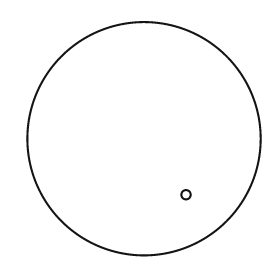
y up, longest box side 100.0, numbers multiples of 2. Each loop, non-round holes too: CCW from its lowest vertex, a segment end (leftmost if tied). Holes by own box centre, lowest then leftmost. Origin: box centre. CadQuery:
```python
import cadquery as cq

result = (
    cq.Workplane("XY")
    .moveTo(0.0, 0.0)
    .circle(50.0)
    .moveTo(18.0, -24.0)
    .circle(2.0)
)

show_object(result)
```